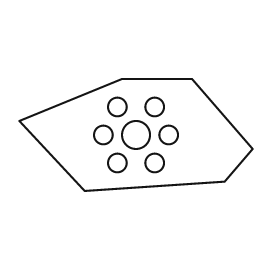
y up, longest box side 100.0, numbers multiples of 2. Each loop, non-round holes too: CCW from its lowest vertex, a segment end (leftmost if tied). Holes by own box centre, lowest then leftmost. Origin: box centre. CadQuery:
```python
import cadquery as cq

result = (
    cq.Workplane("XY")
    .moveTo(-22.0, -24.0)
    .lineTo(38.0, -20.0)
    .lineTo(50.0, -6.0)
    .lineTo(24.0, 24.0)
    .lineTo(-6.0, 24.0)
    .lineTo(-50.0, 6.0)
    .close()
    .moveTo(-8.0, -12.0)
    .circle(4.0)
    .moveTo(8.0, -12.0)
    .circle(4.0)
    .moveTo(-14.0, 0.0)
    .circle(4.0)
    .moveTo(0.0, 0.0)
    .circle(6.0)
    .moveTo(14.0, 0.0)
    .circle(4.0)
    .moveTo(-8.0, 12.0)
    .circle(4.0)
    .moveTo(8.0, 12.0)
    .circle(4.0)
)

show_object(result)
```